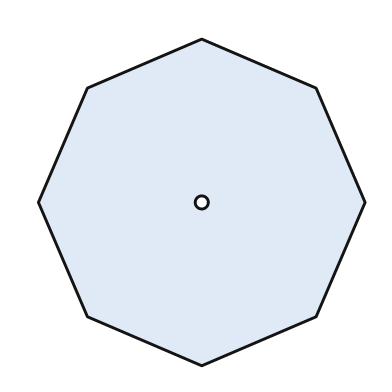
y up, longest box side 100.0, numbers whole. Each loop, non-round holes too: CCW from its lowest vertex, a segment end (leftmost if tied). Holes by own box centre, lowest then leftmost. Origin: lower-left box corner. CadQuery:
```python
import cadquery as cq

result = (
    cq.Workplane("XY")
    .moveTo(50.0, 0.0)
    .lineTo(85.0, 15.0)
    .lineTo(100.0, 50.0)
    .lineTo(85.0, 85.0)
    .lineTo(50.0, 100.0)
    .lineTo(15.0, 85.0)
    .lineTo(0.0, 50.0)
    .lineTo(15.0, 15.0)
    .close()
    .moveTo(50.0, 50.0)
    .circle(2.0)
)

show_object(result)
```